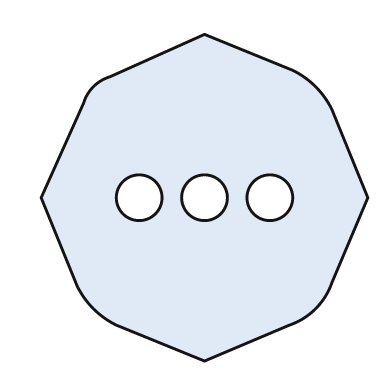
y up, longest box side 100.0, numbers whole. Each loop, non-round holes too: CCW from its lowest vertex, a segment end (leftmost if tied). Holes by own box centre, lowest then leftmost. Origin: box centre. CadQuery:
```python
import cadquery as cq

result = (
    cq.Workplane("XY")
    .moveTo(0.0, -50.0)
    .lineTo(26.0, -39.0)
    .threePointArc((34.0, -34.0), (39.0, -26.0))
    .lineTo(50.0, 0.0)
    .lineTo(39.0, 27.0)
    .threePointArc((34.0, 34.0), (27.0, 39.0))
    .lineTo(0.0, 50.0)
    .lineTo(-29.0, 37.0)
    .threePointArc((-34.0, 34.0), (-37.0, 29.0))
    .lineTo(-50.0, 0.0)
    .lineTo(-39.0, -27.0)
    .threePointArc((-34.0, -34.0), (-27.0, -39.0))
    .close()
    .moveTo(-20.0, 0.0)
    .circle(7.0)
    .moveTo(0.0, 0.0)
    .circle(7.0)
    .moveTo(20.0, 0.0)
    .circle(7.0)
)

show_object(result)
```